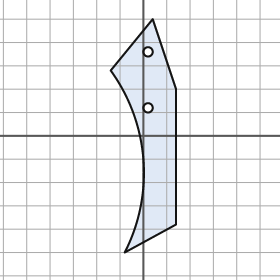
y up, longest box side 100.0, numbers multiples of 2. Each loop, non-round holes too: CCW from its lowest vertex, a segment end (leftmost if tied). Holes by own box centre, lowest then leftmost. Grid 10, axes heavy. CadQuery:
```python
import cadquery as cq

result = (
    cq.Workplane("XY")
    .moveTo(-8.0, -50.0)
    .lineTo(14.0, -38.0)
    .lineTo(14.0, 20.0)
    .lineTo(4.0, 50.0)
    .lineTo(-14.0, 28.0)
    .threePointArc((0.0, -10.0), (-8.0, -50.0))
    .close()
    .moveTo(2.0, 12.0)
    .circle(2.0)
    .moveTo(2.0, 36.0)
    .circle(2.0)
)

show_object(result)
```